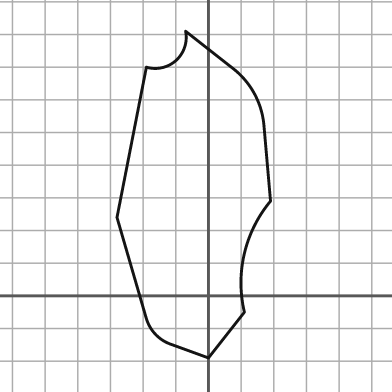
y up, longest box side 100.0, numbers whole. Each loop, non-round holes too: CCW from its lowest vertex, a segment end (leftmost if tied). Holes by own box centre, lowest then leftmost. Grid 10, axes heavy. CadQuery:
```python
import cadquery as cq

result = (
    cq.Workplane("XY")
    .moveTo(0.0, -19.0)
    .lineTo(11.0, -5.0)
    .threePointArc((11.0, 13.0), (19.0, 29.0))
    .lineTo(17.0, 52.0)
    .threePointArc((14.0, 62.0), (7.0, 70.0))
    .lineTo(-7.0, 81.0)
    .threePointArc((-10.0, 72.0), (-19.0, 70.0))
    .lineTo(-28.0, 24.0)
    .lineTo(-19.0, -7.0)
    .threePointArc((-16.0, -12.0), (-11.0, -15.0))
    .close()
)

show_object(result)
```